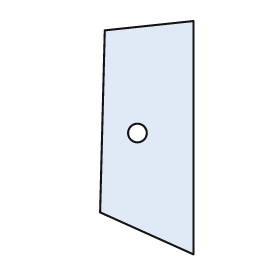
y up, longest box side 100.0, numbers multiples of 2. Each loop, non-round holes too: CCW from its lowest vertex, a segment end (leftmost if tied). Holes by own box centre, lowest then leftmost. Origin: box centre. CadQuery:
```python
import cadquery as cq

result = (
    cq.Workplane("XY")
    .moveTo(20.0, -50.0)
    .lineTo(20.0, 50.0)
    .lineTo(-18.0, 46.0)
    .lineTo(-20.0, -32.0)
    .close()
    .moveTo(-4.0, 2.0)
    .circle(4.0)
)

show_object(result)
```